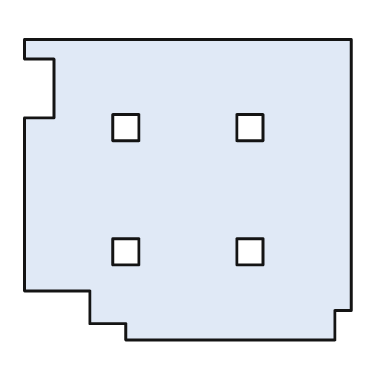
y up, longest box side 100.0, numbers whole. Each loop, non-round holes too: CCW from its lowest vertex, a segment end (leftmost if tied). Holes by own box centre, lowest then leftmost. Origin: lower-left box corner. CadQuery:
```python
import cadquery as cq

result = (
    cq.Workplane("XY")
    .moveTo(31.0, 0.0)
    .lineTo(95.0, 0.0)
    .lineTo(95.0, 9.0)
    .lineTo(100.0, 9.0)
    .lineTo(100.0, 92.0)
    .lineTo(0.0, 92.0)
    .lineTo(0.0, 86.0)
    .lineTo(9.0, 86.0)
    .lineTo(9.0, 68.0)
    .lineTo(0.0, 68.0)
    .lineTo(0.0, 15.0)
    .lineTo(20.0, 15.0)
    .lineTo(20.0, 5.0)
    .lineTo(31.0, 5.0)
    .close()
    .moveTo(27.0, 23.0)
    .lineTo(35.0, 23.0)
    .lineTo(35.0, 31.0)
    .lineTo(27.0, 31.0)
    .close()
    .moveTo(65.0, 23.0)
    .lineTo(73.0, 23.0)
    .lineTo(73.0, 31.0)
    .lineTo(65.0, 31.0)
    .close()
    .moveTo(27.0, 61.0)
    .lineTo(35.0, 61.0)
    .lineTo(35.0, 69.0)
    .lineTo(27.0, 69.0)
    .close()
    .moveTo(65.0, 61.0)
    .lineTo(73.0, 61.0)
    .lineTo(73.0, 69.0)
    .lineTo(65.0, 69.0)
    .close()
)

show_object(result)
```